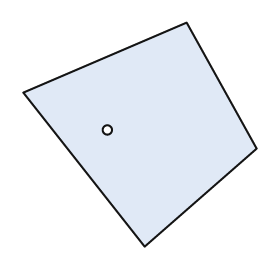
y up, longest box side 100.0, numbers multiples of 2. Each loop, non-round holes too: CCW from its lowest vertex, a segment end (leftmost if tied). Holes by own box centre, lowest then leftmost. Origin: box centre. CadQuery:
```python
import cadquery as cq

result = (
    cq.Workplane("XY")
    .moveTo(2.0, -48.0)
    .lineTo(50.0, -6.0)
    .lineTo(20.0, 48.0)
    .lineTo(-50.0, 18.0)
    .close()
    .moveTo(-14.0, 2.0)
    .circle(2.0)
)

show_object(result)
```